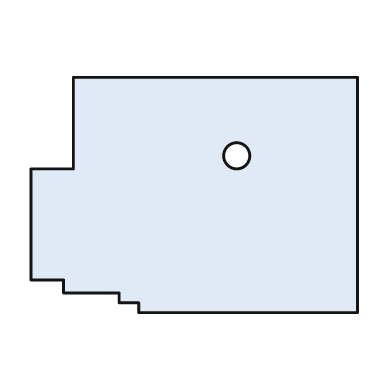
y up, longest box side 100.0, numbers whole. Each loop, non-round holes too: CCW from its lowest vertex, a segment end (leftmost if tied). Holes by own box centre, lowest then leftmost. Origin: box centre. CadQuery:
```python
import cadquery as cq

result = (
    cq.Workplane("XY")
    .moveTo(-17.0, -36.0)
    .lineTo(50.0, -36.0)
    .lineTo(50.0, 36.0)
    .lineTo(-37.0, 36.0)
    .lineTo(-37.0, 8.0)
    .lineTo(-50.0, 8.0)
    .lineTo(-50.0, -26.0)
    .lineTo(-40.0, -26.0)
    .lineTo(-40.0, -30.0)
    .lineTo(-23.0, -30.0)
    .lineTo(-23.0, -33.0)
    .lineTo(-17.0, -33.0)
    .close()
    .moveTo(13.0, 12.0)
    .circle(4.0)
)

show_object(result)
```